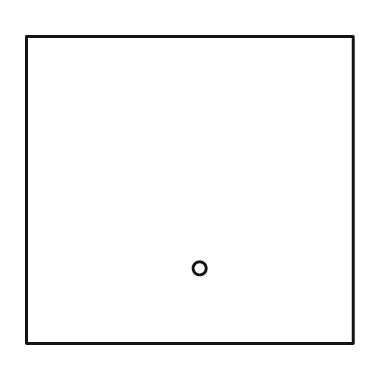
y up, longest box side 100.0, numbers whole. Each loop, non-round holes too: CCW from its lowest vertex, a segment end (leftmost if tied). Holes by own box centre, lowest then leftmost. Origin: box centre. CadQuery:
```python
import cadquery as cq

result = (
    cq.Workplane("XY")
    .moveTo(-50.0, -47.0)
    .lineTo(50.0, -47.0)
    .lineTo(50.0, 47.0)
    .lineTo(-50.0, 47.0)
    .close()
    .moveTo(3.0, -24.0)
    .circle(2.0)
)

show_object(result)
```